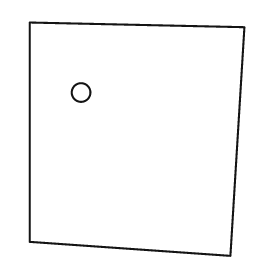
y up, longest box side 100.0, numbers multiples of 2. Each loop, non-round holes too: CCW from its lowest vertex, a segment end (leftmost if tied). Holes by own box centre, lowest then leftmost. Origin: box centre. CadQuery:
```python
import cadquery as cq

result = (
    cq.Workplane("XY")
    .moveTo(40.0, -50.0)
    .lineTo(46.0, 48.0)
    .lineTo(-46.0, 50.0)
    .lineTo(-46.0, -44.0)
    .close()
    .moveTo(-24.0, 20.0)
    .circle(4.0)
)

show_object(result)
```